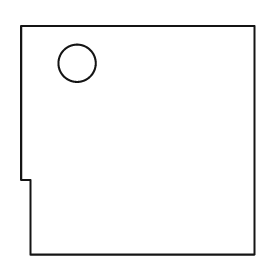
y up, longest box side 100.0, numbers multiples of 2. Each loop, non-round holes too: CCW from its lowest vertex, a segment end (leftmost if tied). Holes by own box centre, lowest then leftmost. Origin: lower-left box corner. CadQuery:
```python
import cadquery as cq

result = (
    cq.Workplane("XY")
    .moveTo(4.0, 0.0)
    .lineTo(100.0, 0.0)
    .lineTo(100.0, 98.0)
    .lineTo(0.0, 98.0)
    .lineTo(0.0, 32.0)
    .lineTo(4.0, 32.0)
    .close()
    .moveTo(24.0, 82.0)
    .circle(8.0)
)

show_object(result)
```